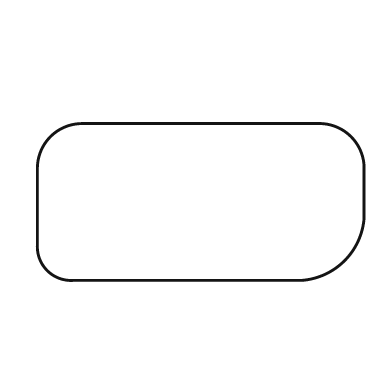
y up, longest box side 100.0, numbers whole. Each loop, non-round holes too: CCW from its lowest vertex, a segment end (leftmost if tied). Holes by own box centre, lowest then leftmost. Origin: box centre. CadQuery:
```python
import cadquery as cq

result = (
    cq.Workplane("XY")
    .moveTo(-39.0, -24.0)
    .lineTo(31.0, -24.0)
    .threePointArc((44.0, -18.0), (50.0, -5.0))
    .lineTo(50.0, 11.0)
    .threePointArc((46.0, 20.0), (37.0, 24.0))
    .lineTo(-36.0, 24.0)
    .threePointArc((-46.0, 20.0), (-50.0, 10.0))
    .lineTo(-50.0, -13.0)
    .threePointArc((-47.0, -21.0), (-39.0, -24.0))
    .close()
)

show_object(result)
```